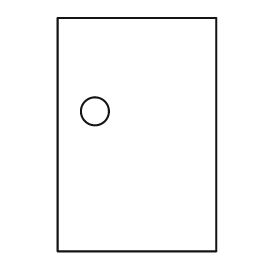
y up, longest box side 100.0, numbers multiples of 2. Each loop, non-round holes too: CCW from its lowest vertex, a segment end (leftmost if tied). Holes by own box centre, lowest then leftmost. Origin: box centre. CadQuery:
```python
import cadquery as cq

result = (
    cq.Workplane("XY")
    .moveTo(-34.0, -50.0)
    .lineTo(34.0, -50.0)
    .lineTo(34.0, 50.0)
    .lineTo(-34.0, 50.0)
    .close()
    .moveTo(-18.0, 10.0)
    .circle(6.0)
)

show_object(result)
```